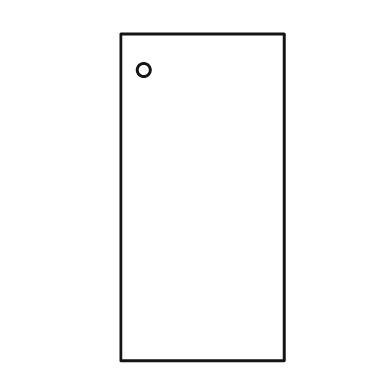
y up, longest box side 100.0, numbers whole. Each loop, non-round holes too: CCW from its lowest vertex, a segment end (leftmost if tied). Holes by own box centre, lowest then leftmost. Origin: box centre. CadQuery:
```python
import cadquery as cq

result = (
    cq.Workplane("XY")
    .moveTo(-25.0, -50.0)
    .lineTo(25.0, -50.0)
    .lineTo(25.0, 50.0)
    .lineTo(-25.0, 50.0)
    .close()
    .moveTo(-18.0, 39.0)
    .circle(2.0)
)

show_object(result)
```